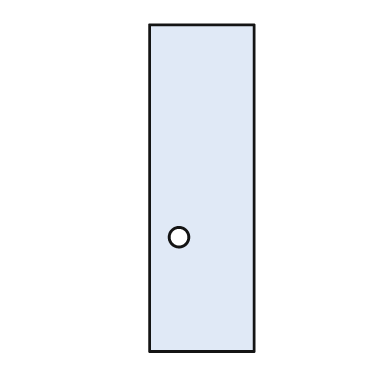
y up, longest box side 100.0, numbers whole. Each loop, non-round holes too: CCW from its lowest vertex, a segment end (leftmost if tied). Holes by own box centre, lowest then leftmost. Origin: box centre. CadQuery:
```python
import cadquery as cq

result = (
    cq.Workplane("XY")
    .moveTo(-16.0, -50.0)
    .lineTo(16.0, -50.0)
    .lineTo(16.0, 50.0)
    .lineTo(-16.0, 50.0)
    .close()
    .moveTo(-7.0, -15.0)
    .circle(3.0)
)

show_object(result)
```